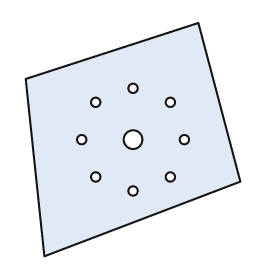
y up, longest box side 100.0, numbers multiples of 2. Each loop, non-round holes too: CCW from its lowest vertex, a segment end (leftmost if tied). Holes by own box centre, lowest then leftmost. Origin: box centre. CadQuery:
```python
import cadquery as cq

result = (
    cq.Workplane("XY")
    .moveTo(-38.0, -50.0)
    .lineTo(46.0, -18.0)
    .lineTo(28.0, 50.0)
    .lineTo(-46.0, 26.0)
    .close()
    .moveTo(0.0, -22.0)
    .circle(2.0)
    .moveTo(-16.0, -16.0)
    .circle(2.0)
    .moveTo(16.0, -16.0)
    .circle(2.0)
    .moveTo(-22.0, 0.0)
    .circle(2.0)
    .moveTo(0.0, 0.0)
    .circle(4.0)
    .moveTo(22.0, 0.0)
    .circle(2.0)
    .moveTo(-16.0, 16.0)
    .circle(2.0)
    .moveTo(16.0, 16.0)
    .circle(2.0)
    .moveTo(0.0, 22.0)
    .circle(2.0)
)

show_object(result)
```